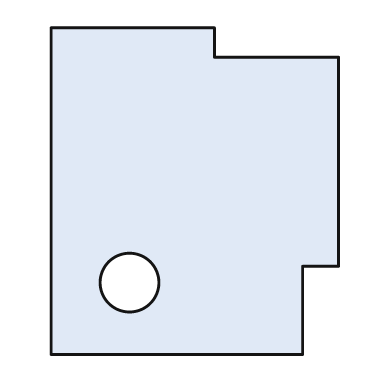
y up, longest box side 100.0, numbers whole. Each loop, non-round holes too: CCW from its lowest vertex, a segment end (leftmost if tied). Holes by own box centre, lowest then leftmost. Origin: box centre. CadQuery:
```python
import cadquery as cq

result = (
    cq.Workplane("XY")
    .moveTo(-44.0, -50.0)
    .lineTo(33.0, -50.0)
    .lineTo(33.0, -23.0)
    .lineTo(44.0, -23.0)
    .lineTo(44.0, 41.0)
    .lineTo(6.0, 41.0)
    .lineTo(6.0, 50.0)
    .lineTo(-44.0, 50.0)
    .close()
    .moveTo(-20.0, -28.0)
    .circle(9.0)
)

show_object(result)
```